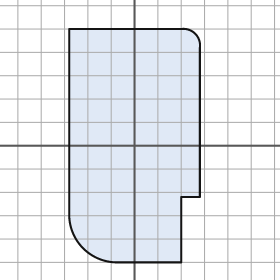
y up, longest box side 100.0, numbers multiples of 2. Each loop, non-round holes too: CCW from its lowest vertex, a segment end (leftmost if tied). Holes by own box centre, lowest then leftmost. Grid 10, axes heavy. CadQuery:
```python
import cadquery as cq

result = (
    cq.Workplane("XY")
    .moveTo(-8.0, -50.0)
    .lineTo(20.0, -50.0)
    .lineTo(20.0, -22.0)
    .lineTo(28.0, -22.0)
    .lineTo(28.0, 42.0)
    .threePointArc((26.0, 48.0), (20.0, 50.0))
    .lineTo(-28.0, 50.0)
    .lineTo(-28.0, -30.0)
    .threePointArc((-22.0, -44.0), (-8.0, -50.0))
    .close()
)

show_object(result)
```